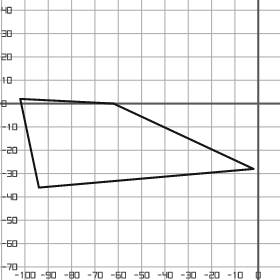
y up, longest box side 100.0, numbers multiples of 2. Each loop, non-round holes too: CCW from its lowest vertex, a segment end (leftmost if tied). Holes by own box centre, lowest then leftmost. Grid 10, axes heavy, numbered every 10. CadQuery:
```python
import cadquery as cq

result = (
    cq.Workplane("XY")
    .moveTo(-94.0, -36.0)
    .lineTo(-2.0, -28.0)
    .lineTo(-62.0, 0.0)
    .lineTo(-102.0, 2.0)
    .close()
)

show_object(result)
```